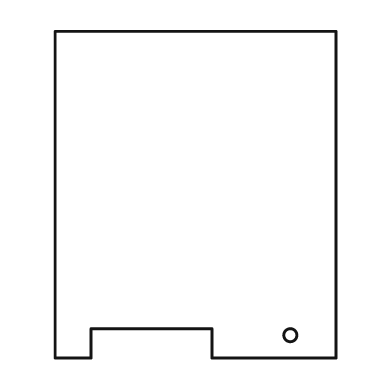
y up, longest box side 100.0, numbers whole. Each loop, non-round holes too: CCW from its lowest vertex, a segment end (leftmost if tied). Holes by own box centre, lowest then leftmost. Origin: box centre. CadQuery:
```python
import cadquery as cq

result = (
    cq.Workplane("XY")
    .moveTo(-43.0, -50.0)
    .lineTo(-32.0, -50.0)
    .lineTo(-32.0, -41.0)
    .lineTo(5.0, -41.0)
    .lineTo(5.0, -50.0)
    .lineTo(43.0, -50.0)
    .lineTo(43.0, 50.0)
    .lineTo(-43.0, 50.0)
    .close()
    .moveTo(29.0, -43.0)
    .circle(2.0)
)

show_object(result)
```